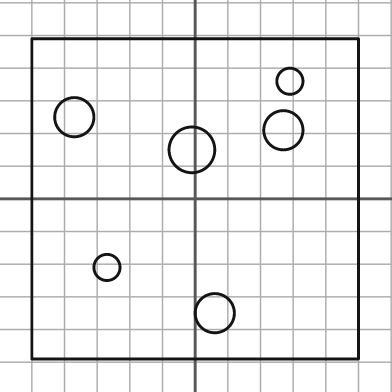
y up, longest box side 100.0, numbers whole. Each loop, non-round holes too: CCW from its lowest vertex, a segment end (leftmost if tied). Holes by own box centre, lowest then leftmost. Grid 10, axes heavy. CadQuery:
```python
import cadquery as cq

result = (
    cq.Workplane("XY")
    .moveTo(-50.0, -49.0)
    .lineTo(50.0, -49.0)
    .lineTo(50.0, 49.0)
    .lineTo(-50.0, 49.0)
    .close()
    .moveTo(6.0, -35.0)
    .circle(6.0)
    .moveTo(-27.0, -21.0)
    .circle(4.0)
    .moveTo(-1.0, 15.0)
    .circle(7.0)
    .moveTo(27.0, 21.0)
    .circle(6.0)
    .moveTo(-37.0, 25.0)
    .circle(6.0)
    .moveTo(29.0, 36.0)
    .circle(4.0)
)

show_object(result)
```